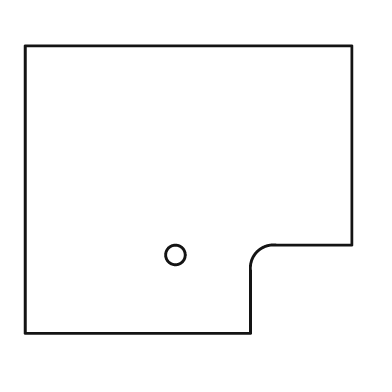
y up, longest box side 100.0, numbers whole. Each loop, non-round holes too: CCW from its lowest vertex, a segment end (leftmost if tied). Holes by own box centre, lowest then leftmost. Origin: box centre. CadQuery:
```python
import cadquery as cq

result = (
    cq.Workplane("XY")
    .moveTo(-50.0, -44.0)
    .lineTo(19.0, -44.0)
    .lineTo(19.0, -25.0)
    .threePointArc((21.0, -19.0), (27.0, -17.0))
    .lineTo(50.0, -17.0)
    .lineTo(50.0, 44.0)
    .lineTo(-50.0, 44.0)
    .close()
    .moveTo(-4.0, -20.0)
    .circle(3.0)
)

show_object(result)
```